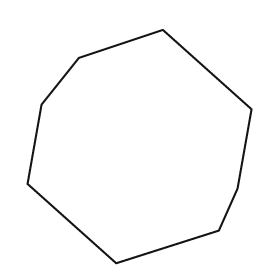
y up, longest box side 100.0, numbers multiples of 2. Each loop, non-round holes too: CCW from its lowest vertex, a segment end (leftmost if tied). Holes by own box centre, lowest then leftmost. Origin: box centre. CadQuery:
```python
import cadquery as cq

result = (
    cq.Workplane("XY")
    .moveTo(-10.0, -50.0)
    .lineTo(34.0, -36.0)
    .lineTo(42.0, -18.0)
    .lineTo(48.0, 16.0)
    .lineTo(10.0, 50.0)
    .lineTo(-26.0, 38.0)
    .lineTo(-42.0, 18.0)
    .lineTo(-48.0, -16.0)
    .close()
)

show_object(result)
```